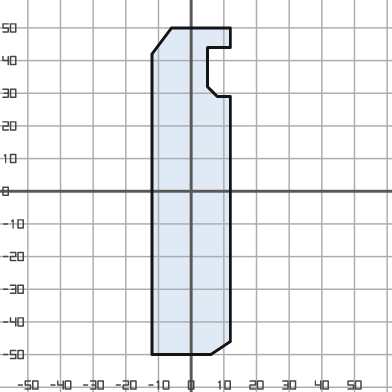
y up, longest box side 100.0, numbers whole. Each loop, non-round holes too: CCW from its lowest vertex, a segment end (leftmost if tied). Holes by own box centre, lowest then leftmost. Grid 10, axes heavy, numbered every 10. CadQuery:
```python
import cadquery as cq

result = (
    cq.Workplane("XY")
    .moveTo(-12.0, -50.0)
    .lineTo(6.0, -50.0)
    .lineTo(12.0, -46.0)
    .lineTo(12.0, 29.0)
    .lineTo(8.0, 29.0)
    .lineTo(5.0, 32.0)
    .lineTo(5.0, 44.0)
    .lineTo(12.0, 44.0)
    .lineTo(12.0, 50.0)
    .lineTo(-6.0, 50.0)
    .lineTo(-12.0, 42.0)
    .close()
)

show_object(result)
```